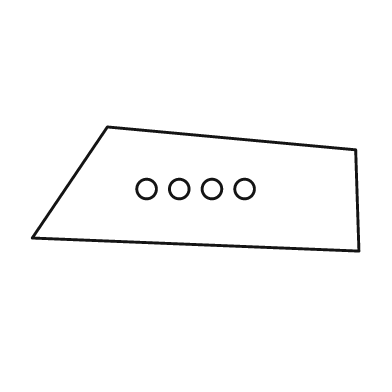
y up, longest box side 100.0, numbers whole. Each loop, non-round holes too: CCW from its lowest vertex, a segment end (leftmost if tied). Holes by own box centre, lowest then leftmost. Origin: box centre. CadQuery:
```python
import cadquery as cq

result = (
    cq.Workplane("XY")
    .moveTo(50.0, -19.0)
    .lineTo(49.0, 12.0)
    .lineTo(-27.0, 19.0)
    .lineTo(-50.0, -15.0)
    .close()
    .moveTo(-15.0, 0.0)
    .circle(3.0)
    .moveTo(-5.0, 0.0)
    .circle(3.0)
    .moveTo(5.0, 0.0)
    .circle(3.0)
    .moveTo(15.0, 0.0)
    .circle(3.0)
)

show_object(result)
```